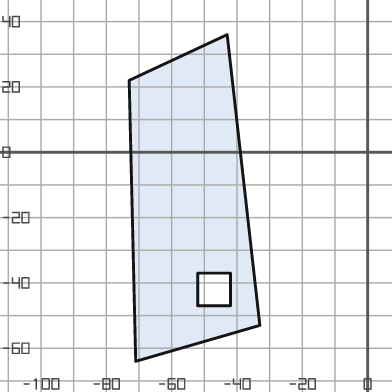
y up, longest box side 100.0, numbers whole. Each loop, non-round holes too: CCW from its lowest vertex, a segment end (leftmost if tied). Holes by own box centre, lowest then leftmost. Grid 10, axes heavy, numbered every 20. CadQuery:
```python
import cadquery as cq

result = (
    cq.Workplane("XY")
    .moveTo(-71.0, -64.0)
    .lineTo(-33.0, -53.0)
    .lineTo(-43.0, 36.0)
    .lineTo(-73.0, 22.0)
    .close()
    .moveTo(-52.0, -47.0)
    .lineTo(-42.0, -47.0)
    .lineTo(-42.0, -37.0)
    .lineTo(-52.0, -37.0)
    .close()
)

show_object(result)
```